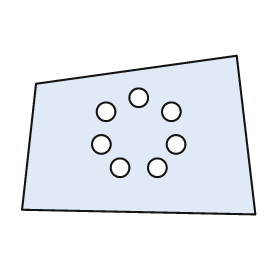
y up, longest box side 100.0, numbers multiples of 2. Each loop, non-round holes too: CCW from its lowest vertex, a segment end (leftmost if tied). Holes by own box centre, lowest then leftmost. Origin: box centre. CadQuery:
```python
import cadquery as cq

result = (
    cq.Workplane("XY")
    .moveTo(50.0, -34.0)
    .lineTo(42.0, 34.0)
    .lineTo(-44.0, 22.0)
    .lineTo(-50.0, -32.0)
    .close()
    .moveTo(-8.0, -14.0)
    .circle(4.0)
    .moveTo(8.0, -14.0)
    .circle(4.0)
    .moveTo(-16.0, -4.0)
    .circle(4.0)
    .moveTo(16.0, -4.0)
    .circle(4.0)
    .moveTo(-14.0, 10.0)
    .circle(4.0)
    .moveTo(14.0, 10.0)
    .circle(4.0)
    .moveTo(0.0, 16.0)
    .circle(4.0)
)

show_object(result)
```